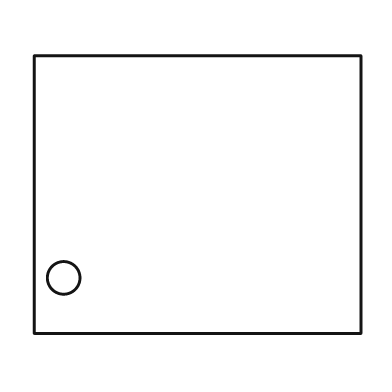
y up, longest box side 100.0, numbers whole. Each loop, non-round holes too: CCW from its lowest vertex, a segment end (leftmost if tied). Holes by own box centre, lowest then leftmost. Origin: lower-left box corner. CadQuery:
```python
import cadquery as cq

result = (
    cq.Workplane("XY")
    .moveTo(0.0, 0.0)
    .lineTo(100.0, 0.0)
    .lineTo(100.0, 85.0)
    .lineTo(0.0, 85.0)
    .close()
    .moveTo(9.0, 17.0)
    .circle(5.0)
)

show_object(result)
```